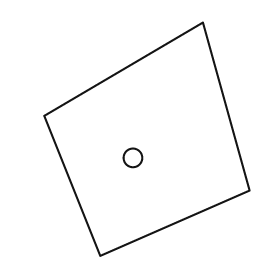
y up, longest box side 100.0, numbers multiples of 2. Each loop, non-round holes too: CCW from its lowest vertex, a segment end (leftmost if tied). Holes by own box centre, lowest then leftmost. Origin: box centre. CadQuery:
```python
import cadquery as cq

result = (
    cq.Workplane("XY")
    .moveTo(-20.0, -50.0)
    .lineTo(44.0, -22.0)
    .lineTo(24.0, 50.0)
    .lineTo(-44.0, 10.0)
    .close()
    .moveTo(-6.0, -8.0)
    .circle(4.0)
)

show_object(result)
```